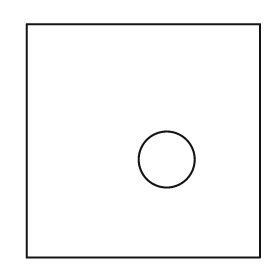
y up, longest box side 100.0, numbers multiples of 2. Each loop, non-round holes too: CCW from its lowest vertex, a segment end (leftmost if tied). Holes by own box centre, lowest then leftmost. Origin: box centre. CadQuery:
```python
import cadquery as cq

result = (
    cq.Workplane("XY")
    .moveTo(-50.0, -50.0)
    .lineTo(50.0, -50.0)
    .lineTo(50.0, 50.0)
    .lineTo(-50.0, 50.0)
    .close()
    .moveTo(10.0, -8.0)
    .circle(12.0)
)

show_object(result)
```